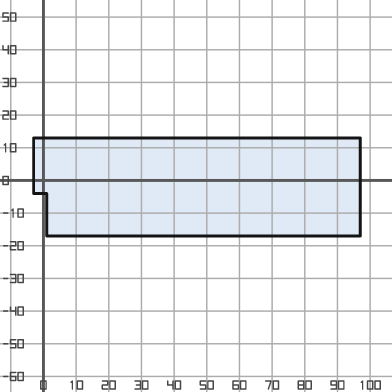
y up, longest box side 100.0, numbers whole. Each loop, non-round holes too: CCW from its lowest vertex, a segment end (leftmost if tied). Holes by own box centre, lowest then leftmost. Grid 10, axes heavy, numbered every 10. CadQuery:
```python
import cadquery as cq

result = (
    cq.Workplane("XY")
    .moveTo(1.0, -17.0)
    .lineTo(97.0, -17.0)
    .lineTo(97.0, 13.0)
    .lineTo(-3.0, 13.0)
    .lineTo(-3.0, -4.0)
    .lineTo(1.0, -4.0)
    .close()
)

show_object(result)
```